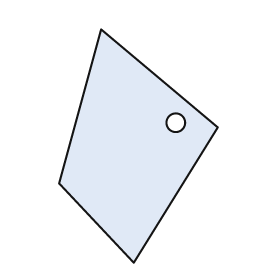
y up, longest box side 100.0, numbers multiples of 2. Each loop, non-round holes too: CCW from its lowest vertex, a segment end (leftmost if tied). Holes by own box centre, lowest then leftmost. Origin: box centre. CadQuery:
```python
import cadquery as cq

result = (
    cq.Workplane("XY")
    .moveTo(-2.0, -50.0)
    .lineTo(34.0, 8.0)
    .lineTo(-16.0, 50.0)
    .lineTo(-34.0, -16.0)
    .close()
    .moveTo(16.0, 10.0)
    .circle(4.0)
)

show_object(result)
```